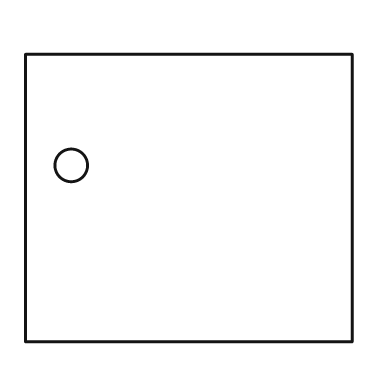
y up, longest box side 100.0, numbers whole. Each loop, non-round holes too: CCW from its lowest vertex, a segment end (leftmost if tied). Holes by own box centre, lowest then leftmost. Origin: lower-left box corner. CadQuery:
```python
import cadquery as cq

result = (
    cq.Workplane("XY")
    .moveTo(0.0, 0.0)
    .lineTo(100.0, 0.0)
    .lineTo(100.0, 88.0)
    .lineTo(0.0, 88.0)
    .close()
    .moveTo(14.0, 54.0)
    .circle(5.0)
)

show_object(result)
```